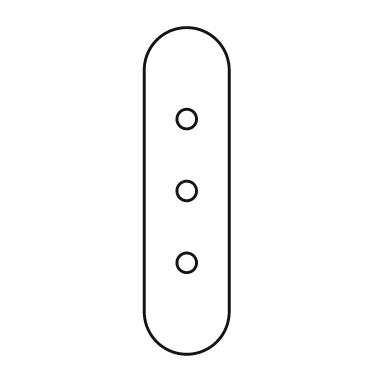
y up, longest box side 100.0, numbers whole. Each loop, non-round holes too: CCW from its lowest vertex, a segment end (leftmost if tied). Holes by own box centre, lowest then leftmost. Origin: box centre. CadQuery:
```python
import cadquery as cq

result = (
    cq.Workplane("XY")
    .moveTo(-13.0, -37.0)
    .threePointArc((0.0, -50.0), (13.0, -37.0))
    .lineTo(13.0, 37.0)
    .threePointArc((0.0, 50.0), (-13.0, 37.0))
    .close()
    .moveTo(0.0, -22.0)
    .circle(3.0)
    .moveTo(0.0, 0.0)
    .circle(3.0)
    .moveTo(0.0, 22.0)
    .circle(3.0)
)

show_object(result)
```